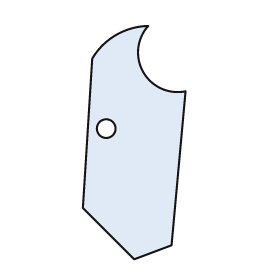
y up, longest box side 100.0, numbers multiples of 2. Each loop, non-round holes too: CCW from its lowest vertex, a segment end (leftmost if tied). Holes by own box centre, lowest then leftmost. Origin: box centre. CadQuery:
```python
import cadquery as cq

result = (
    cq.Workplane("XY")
    .moveTo(0.0, -50.0)
    .lineTo(16.0, -44.0)
    .lineTo(22.0, 22.0)
    .threePointArc((4.0, 30.0), (6.0, 50.0))
    .threePointArc((-8.0, 46.0), (-18.0, 36.0))
    .lineTo(-22.0, -28.0)
    .close()
    .moveTo(-12.0, 6.0)
    .circle(4.0)
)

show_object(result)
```